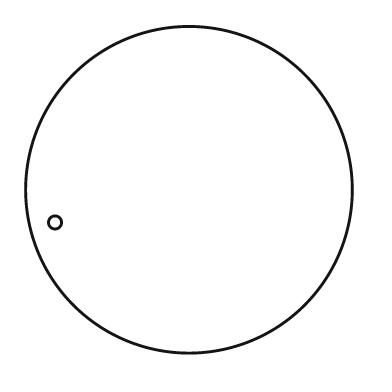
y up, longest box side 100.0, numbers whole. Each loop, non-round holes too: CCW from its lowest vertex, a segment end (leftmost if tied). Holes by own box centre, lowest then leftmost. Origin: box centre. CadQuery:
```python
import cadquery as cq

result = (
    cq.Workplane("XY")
    .moveTo(0.0, 0.0)
    .circle(50.0)
    .moveTo(-41.0, -10.0)
    .circle(2.0)
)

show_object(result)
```